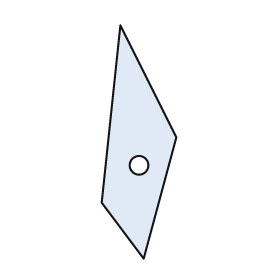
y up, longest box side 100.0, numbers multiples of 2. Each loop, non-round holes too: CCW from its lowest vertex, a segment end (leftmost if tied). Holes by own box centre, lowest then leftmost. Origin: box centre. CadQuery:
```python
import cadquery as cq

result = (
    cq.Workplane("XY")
    .moveTo(2.0, -50.0)
    .lineTo(16.0, 2.0)
    .lineTo(-8.0, 50.0)
    .lineTo(-16.0, -26.0)
    .close()
    .moveTo(0.0, -10.0)
    .circle(4.0)
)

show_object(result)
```